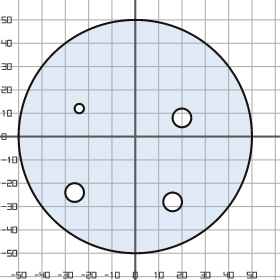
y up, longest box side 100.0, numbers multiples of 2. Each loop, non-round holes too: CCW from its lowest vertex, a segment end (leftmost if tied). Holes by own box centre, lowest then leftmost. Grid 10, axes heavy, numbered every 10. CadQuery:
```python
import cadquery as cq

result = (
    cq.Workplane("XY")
    .moveTo(0.0, 0.0)
    .circle(50.0)
    .moveTo(16.0, -28.0)
    .circle(4.0)
    .moveTo(-26.0, -24.0)
    .circle(4.0)
    .moveTo(20.0, 8.0)
    .circle(4.0)
    .moveTo(-24.0, 12.0)
    .circle(2.0)
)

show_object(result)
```